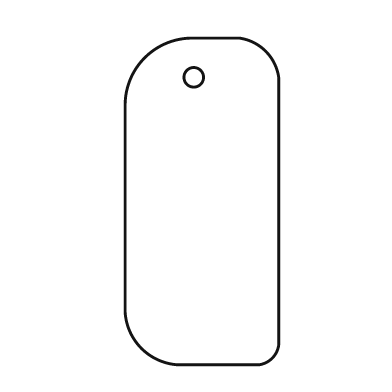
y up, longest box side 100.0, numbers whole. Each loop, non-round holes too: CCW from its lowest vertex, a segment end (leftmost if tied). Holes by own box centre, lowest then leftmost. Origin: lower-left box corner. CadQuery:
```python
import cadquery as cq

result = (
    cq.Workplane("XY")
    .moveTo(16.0, 0.0)
    .lineTo(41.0, 0.0)
    .threePointArc((45.0, 2.0), (47.0, 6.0))
    .lineTo(47.0, 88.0)
    .threePointArc((43.0, 96.0), (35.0, 100.0))
    .lineTo(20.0, 100.0)
    .threePointArc((6.0, 94.0), (0.0, 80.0))
    .lineTo(0.0, 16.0)
    .threePointArc((5.0, 5.0), (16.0, 0.0))
    .close()
    .moveTo(21.0, 88.0)
    .circle(3.0)
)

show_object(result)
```